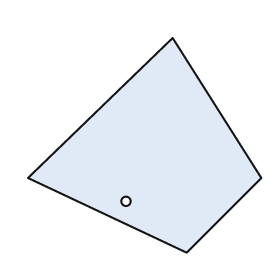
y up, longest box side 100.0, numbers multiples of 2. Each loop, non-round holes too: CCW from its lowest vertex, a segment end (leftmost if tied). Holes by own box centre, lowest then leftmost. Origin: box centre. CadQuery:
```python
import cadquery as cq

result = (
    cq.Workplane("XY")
    .moveTo(18.0, -46.0)
    .lineTo(50.0, -14.0)
    .lineTo(12.0, 46.0)
    .lineTo(-50.0, -14.0)
    .close()
    .moveTo(-8.0, -24.0)
    .circle(2.0)
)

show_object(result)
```